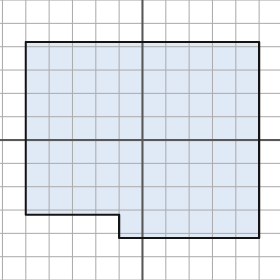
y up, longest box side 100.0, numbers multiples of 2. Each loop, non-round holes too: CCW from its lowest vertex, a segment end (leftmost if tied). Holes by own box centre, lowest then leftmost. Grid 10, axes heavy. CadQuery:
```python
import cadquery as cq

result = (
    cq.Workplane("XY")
    .moveTo(-10.0, -42.0)
    .lineTo(50.0, -42.0)
    .lineTo(50.0, 42.0)
    .lineTo(-50.0, 42.0)
    .lineTo(-50.0, -32.0)
    .lineTo(-10.0, -32.0)
    .close()
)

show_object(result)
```